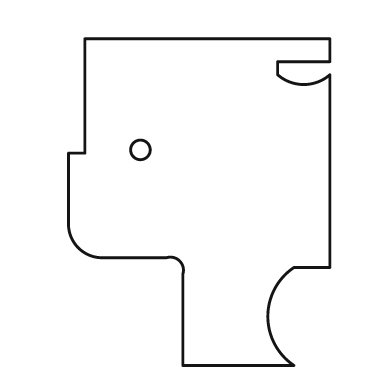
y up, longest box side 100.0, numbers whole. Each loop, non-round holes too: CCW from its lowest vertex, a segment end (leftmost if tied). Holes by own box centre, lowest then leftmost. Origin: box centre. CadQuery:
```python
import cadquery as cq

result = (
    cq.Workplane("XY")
    .moveTo(-5.0, -50.0)
    .lineTo(29.0, -50.0)
    .threePointArc((21.0, -35.0), (29.0, -20.0))
    .lineTo(40.0, -20.0)
    .lineTo(40.0, 39.0)
    .threePointArc((32.0, 36.0), (24.0, 39.0))
    .lineTo(24.0, 43.0)
    .lineTo(40.0, 43.0)
    .lineTo(40.0, 50.0)
    .lineTo(-35.0, 50.0)
    .lineTo(-35.0, 15.0)
    .lineTo(-40.0, 15.0)
    .lineTo(-40.0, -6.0)
    .threePointArc((-37.0, -14.0), (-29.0, -17.0))
    .lineTo(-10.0, -17.0)
    .threePointArc((-6.0, -18.0), (-5.0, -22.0))
    .close()
    .moveTo(-18.0, 16.0)
    .circle(3.0)
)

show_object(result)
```